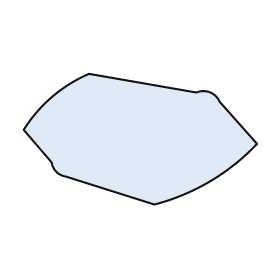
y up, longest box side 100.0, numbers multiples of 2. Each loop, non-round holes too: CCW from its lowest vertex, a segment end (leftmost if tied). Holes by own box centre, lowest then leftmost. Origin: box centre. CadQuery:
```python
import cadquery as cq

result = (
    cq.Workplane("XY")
    .moveTo(6.0, -28.0)
    .threePointArc((30.0, -18.0), (50.0, -2.0))
    .lineTo(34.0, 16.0)
    .threePointArc((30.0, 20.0), (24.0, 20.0))
    .lineTo(-22.0, 28.0)
    .threePointArc((-38.0, 18.0), (-50.0, 4.0))
    .lineTo(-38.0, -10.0)
    .threePointArc((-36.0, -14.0), (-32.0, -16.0))
    .close()
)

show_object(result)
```